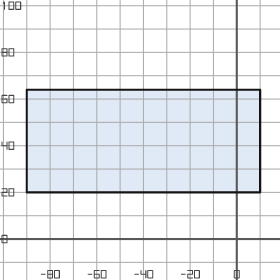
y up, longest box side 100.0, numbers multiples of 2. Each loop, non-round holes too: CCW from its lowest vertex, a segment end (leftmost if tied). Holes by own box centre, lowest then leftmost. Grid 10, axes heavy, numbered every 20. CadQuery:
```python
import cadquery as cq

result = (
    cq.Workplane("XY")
    .moveTo(-90.0, 20.0)
    .lineTo(10.0, 20.0)
    .lineTo(10.0, 64.0)
    .lineTo(-90.0, 64.0)
    .close()
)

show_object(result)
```